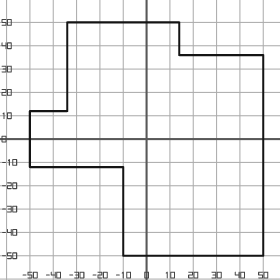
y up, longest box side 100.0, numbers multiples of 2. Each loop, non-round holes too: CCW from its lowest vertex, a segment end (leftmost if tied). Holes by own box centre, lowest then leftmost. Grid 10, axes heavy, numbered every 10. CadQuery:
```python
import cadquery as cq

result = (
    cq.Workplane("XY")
    .moveTo(-10.0, -50.0)
    .lineTo(50.0, -50.0)
    .lineTo(50.0, 36.0)
    .lineTo(14.0, 36.0)
    .lineTo(14.0, 50.0)
    .lineTo(-34.0, 50.0)
    .lineTo(-34.0, 12.0)
    .lineTo(-50.0, 12.0)
    .lineTo(-50.0, -12.0)
    .lineTo(-10.0, -12.0)
    .close()
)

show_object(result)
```